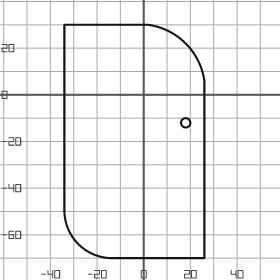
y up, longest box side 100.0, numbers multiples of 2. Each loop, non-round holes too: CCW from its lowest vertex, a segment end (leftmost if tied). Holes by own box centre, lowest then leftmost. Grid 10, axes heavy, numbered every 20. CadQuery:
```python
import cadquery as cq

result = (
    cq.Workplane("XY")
    .moveTo(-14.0, -70.0)
    .lineTo(26.0, -70.0)
    .lineTo(26.0, 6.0)
    .threePointArc((18.0, 22.0), (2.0, 30.0))
    .lineTo(-34.0, 30.0)
    .lineTo(-34.0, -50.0)
    .threePointArc((-28.0, -64.0), (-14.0, -70.0))
    .close()
    .moveTo(18.0, -12.0)
    .circle(2.0)
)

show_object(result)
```